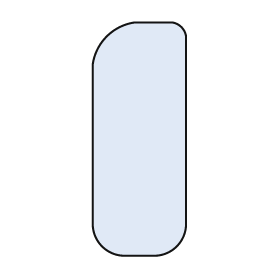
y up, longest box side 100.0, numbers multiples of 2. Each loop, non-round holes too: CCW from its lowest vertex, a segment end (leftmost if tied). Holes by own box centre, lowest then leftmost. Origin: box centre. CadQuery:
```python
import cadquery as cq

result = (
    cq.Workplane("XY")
    .moveTo(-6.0, -50.0)
    .lineTo(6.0, -50.0)
    .threePointArc((16.0, -46.0), (20.0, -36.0))
    .lineTo(20.0, 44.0)
    .threePointArc((18.0, 48.0), (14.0, 50.0))
    .lineTo(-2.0, 50.0)
    .threePointArc((-14.0, 44.0), (-20.0, 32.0))
    .lineTo(-20.0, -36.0)
    .threePointArc((-16.0, -46.0), (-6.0, -50.0))
    .close()
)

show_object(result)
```